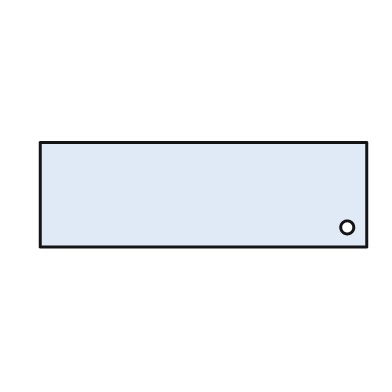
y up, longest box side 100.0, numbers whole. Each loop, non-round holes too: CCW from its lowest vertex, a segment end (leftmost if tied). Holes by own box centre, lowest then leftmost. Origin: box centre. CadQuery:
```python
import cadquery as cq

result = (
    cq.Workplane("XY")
    .moveTo(-50.0, -16.0)
    .lineTo(50.0, -16.0)
    .lineTo(50.0, 16.0)
    .lineTo(-50.0, 16.0)
    .close()
    .moveTo(44.0, -10.0)
    .circle(2.0)
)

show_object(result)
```